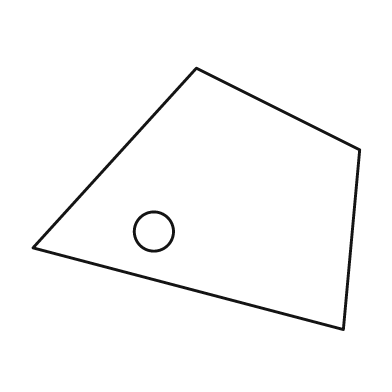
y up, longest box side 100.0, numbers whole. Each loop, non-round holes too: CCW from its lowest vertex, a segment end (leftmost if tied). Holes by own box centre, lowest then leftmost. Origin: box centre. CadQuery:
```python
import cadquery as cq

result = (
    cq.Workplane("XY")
    .moveTo(45.0, -40.0)
    .lineTo(50.0, 15.0)
    .lineTo(0.0, 40.0)
    .lineTo(-50.0, -15.0)
    .close()
    .moveTo(-13.0, -10.0)
    .circle(6.0)
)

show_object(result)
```